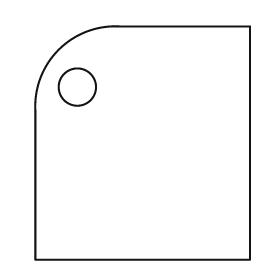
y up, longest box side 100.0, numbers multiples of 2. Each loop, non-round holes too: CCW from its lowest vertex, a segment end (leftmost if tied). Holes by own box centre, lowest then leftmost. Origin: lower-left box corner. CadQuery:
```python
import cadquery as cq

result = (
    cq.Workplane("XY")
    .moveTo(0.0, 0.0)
    .lineTo(92.0, 0.0)
    .lineTo(92.0, 100.0)
    .lineTo(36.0, 100.0)
    .threePointArc((10.0, 90.0), (0.0, 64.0))
    .close()
    .moveTo(18.0, 74.0)
    .circle(8.0)
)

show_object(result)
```